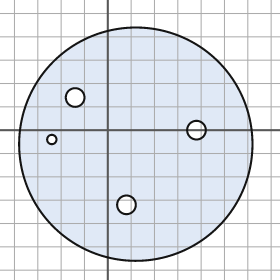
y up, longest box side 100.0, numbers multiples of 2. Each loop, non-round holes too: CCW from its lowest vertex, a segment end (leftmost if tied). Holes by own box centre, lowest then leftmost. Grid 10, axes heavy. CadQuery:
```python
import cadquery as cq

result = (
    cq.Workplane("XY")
    .moveTo(12.0, -6.0)
    .circle(50.0)
    .moveTo(8.0, -32.0)
    .circle(4.0)
    .moveTo(-24.0, -4.0)
    .circle(2.0)
    .moveTo(38.0, 0.0)
    .circle(4.0)
    .moveTo(-14.0, 14.0)
    .circle(4.0)
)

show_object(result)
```